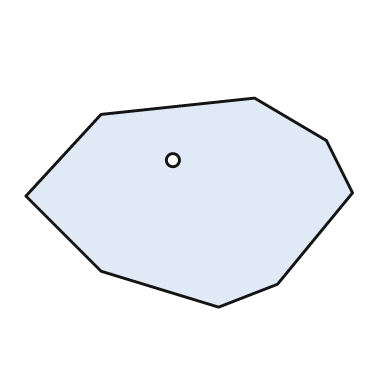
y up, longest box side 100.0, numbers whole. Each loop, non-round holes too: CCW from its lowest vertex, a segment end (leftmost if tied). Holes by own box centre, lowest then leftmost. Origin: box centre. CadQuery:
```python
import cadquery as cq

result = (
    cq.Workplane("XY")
    .moveTo(9.0, -32.0)
    .lineTo(27.0, -25.0)
    .lineTo(50.0, 3.0)
    .lineTo(42.0, 19.0)
    .lineTo(20.0, 32.0)
    .lineTo(-27.0, 27.0)
    .lineTo(-50.0, 2.0)
    .lineTo(-27.0, -21.0)
    .close()
    .moveTo(-5.0, 13.0)
    .circle(2.0)
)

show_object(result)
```